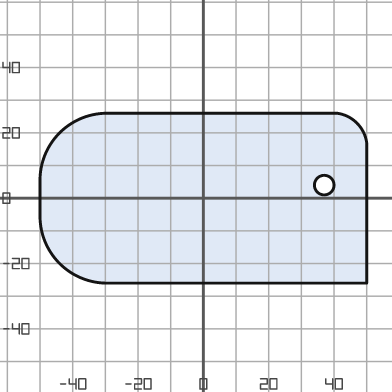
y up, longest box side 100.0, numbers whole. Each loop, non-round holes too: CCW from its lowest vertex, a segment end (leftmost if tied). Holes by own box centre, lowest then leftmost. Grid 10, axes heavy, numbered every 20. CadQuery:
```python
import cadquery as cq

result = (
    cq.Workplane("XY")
    .moveTo(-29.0, -26.0)
    .lineTo(50.0, -26.0)
    .lineTo(50.0, 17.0)
    .threePointArc((47.0, 23.0), (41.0, 26.0))
    .lineTo(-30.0, 26.0)
    .threePointArc((-44.0, 20.0), (-50.0, 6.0))
    .lineTo(-50.0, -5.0)
    .threePointArc((-44.0, -20.0), (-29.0, -26.0))
    .close()
    .moveTo(37.0, 4.0)
    .circle(3.0)
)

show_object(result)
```